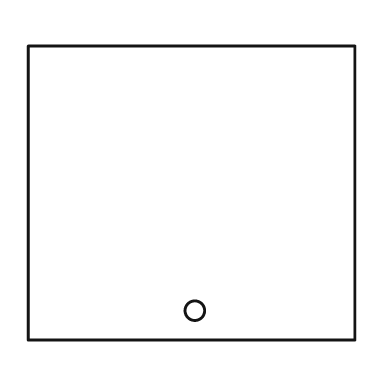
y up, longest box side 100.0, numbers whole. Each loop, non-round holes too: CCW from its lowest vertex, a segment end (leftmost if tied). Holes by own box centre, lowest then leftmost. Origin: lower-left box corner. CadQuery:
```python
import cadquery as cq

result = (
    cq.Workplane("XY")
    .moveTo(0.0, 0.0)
    .lineTo(100.0, 0.0)
    .lineTo(100.0, 90.0)
    .lineTo(0.0, 90.0)
    .close()
    .moveTo(51.0, 9.0)
    .circle(3.0)
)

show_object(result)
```